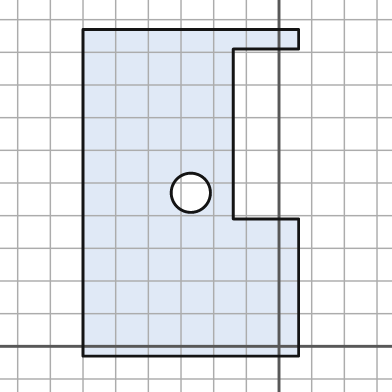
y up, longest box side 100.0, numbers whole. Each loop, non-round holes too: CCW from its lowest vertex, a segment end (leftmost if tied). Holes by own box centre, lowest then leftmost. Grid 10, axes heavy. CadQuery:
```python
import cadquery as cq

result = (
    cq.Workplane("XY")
    .moveTo(-60.0, -3.0)
    .lineTo(6.0, -3.0)
    .lineTo(6.0, 39.0)
    .lineTo(-14.0, 39.0)
    .lineTo(-14.0, 91.0)
    .lineTo(6.0, 91.0)
    .lineTo(6.0, 97.0)
    .lineTo(-60.0, 97.0)
    .close()
    .moveTo(-27.0, 47.0)
    .circle(6.0)
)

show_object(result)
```